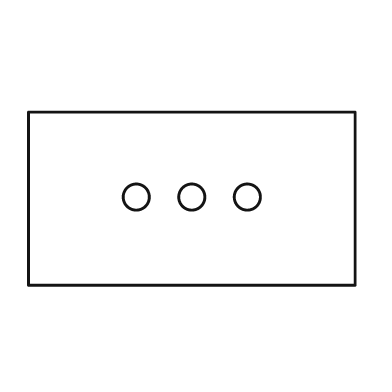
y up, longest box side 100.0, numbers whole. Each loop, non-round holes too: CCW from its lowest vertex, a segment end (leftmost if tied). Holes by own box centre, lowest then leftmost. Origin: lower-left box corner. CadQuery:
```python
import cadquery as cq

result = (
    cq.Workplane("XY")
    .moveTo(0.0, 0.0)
    .lineTo(100.0, 0.0)
    .lineTo(100.0, 53.0)
    .lineTo(0.0, 53.0)
    .close()
    .moveTo(33.0, 27.0)
    .circle(4.0)
    .moveTo(50.0, 27.0)
    .circle(4.0)
    .moveTo(67.0, 27.0)
    .circle(4.0)
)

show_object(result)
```